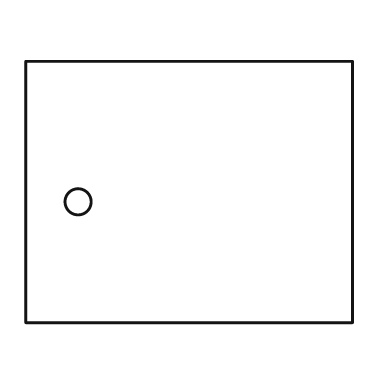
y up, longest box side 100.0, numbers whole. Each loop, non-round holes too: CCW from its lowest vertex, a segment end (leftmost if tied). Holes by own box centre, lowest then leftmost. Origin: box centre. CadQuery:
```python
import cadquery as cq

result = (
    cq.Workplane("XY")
    .moveTo(-50.0, -40.0)
    .lineTo(50.0, -40.0)
    .lineTo(50.0, 40.0)
    .lineTo(-50.0, 40.0)
    .close()
    .moveTo(-34.0, -3.0)
    .circle(4.0)
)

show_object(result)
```